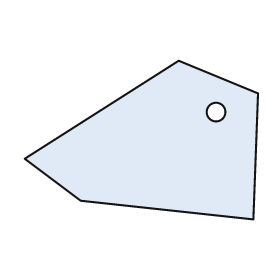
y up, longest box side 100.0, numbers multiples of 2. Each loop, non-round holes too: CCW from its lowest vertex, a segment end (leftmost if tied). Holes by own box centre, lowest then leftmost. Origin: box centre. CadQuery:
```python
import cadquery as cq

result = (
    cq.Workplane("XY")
    .moveTo(48.0, -34.0)
    .lineTo(50.0, 20.0)
    .lineTo(16.0, 34.0)
    .lineTo(-50.0, -8.0)
    .lineTo(-26.0, -26.0)
    .close()
    .moveTo(32.0, 12.0)
    .circle(4.0)
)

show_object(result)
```